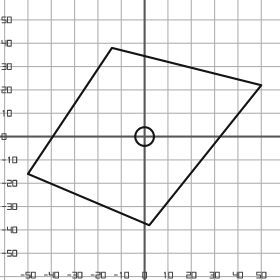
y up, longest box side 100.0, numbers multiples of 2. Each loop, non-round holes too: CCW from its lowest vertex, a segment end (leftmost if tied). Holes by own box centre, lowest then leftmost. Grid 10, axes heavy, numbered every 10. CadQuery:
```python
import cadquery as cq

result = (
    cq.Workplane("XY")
    .moveTo(2.0, -38.0)
    .lineTo(50.0, 22.0)
    .lineTo(-14.0, 38.0)
    .lineTo(-50.0, -16.0)
    .close()
    .moveTo(0.0, 0.0)
    .circle(4.0)
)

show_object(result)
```